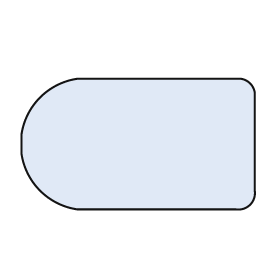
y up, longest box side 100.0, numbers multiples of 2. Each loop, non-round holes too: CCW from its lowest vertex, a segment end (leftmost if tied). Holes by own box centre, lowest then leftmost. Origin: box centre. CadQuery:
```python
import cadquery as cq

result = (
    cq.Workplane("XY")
    .moveTo(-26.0, -28.0)
    .lineTo(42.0, -28.0)
    .threePointArc((48.0, -26.0), (50.0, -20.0))
    .lineTo(50.0, 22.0)
    .threePointArc((48.0, 26.0), (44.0, 28.0))
    .lineTo(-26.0, 28.0)
    .threePointArc((-42.0, 20.0), (-50.0, 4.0))
    .lineTo(-50.0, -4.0)
    .threePointArc((-42.0, -20.0), (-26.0, -28.0))
    .close()
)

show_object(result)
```